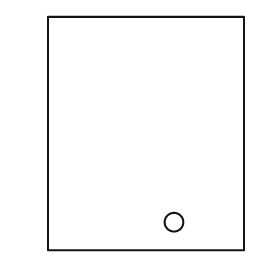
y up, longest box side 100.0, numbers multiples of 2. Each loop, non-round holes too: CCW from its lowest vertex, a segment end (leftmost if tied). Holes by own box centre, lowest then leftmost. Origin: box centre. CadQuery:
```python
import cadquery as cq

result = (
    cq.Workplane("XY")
    .moveTo(-42.0, -50.0)
    .lineTo(42.0, -50.0)
    .lineTo(42.0, 50.0)
    .lineTo(-42.0, 50.0)
    .close()
    .moveTo(12.0, -38.0)
    .circle(4.0)
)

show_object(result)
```